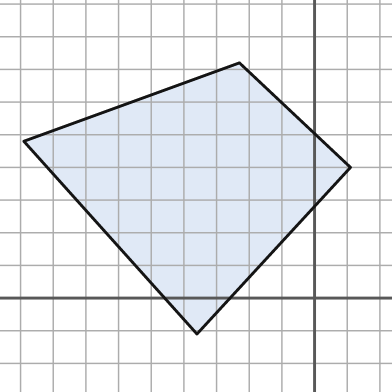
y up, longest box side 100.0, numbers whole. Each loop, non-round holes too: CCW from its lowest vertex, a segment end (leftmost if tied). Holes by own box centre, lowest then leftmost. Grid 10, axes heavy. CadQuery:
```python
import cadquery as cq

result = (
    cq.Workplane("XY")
    .moveTo(-36.0, -11.0)
    .lineTo(11.0, 40.0)
    .lineTo(-23.0, 72.0)
    .lineTo(-89.0, 48.0)
    .close()
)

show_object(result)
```